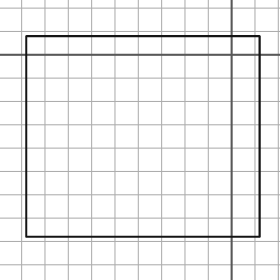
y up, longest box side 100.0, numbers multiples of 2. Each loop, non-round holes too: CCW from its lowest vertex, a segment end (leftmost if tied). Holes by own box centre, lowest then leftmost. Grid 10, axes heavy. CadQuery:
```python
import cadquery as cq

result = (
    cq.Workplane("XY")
    .moveTo(-88.0, -78.0)
    .lineTo(12.0, -78.0)
    .lineTo(12.0, 8.0)
    .lineTo(-88.0, 8.0)
    .close()
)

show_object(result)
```